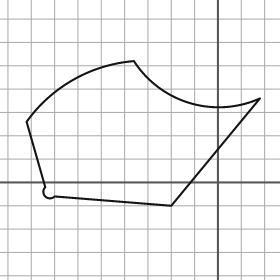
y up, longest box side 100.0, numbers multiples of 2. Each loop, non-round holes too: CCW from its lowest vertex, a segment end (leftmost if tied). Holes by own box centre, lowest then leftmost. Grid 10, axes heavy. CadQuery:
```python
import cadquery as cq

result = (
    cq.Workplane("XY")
    .moveTo(-20.0, -10.0)
    .lineTo(18.0, 36.0)
    .threePointArc((-12.0, 34.0), (-36.0, 52.0))
    .threePointArc((-62.0, 44.0), (-82.0, 26.0))
    .lineTo(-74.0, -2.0)
    .threePointArc((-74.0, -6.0), (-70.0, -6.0))
    .close()
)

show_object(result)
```